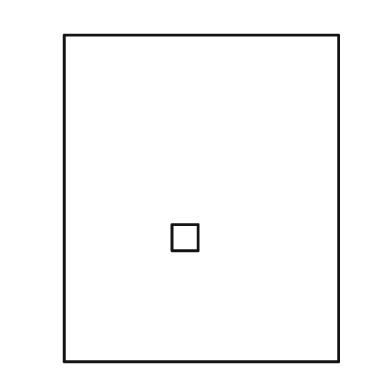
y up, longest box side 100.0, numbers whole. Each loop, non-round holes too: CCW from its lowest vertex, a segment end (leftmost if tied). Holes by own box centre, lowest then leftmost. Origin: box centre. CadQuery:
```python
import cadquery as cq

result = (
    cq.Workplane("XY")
    .moveTo(-42.0, -50.0)
    .lineTo(42.0, -50.0)
    .lineTo(42.0, 50.0)
    .lineTo(-42.0, 50.0)
    .close()
    .moveTo(-9.0, -16.0)
    .lineTo(-1.0, -16.0)
    .lineTo(-1.0, -8.0)
    .lineTo(-9.0, -8.0)
    .close()
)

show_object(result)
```